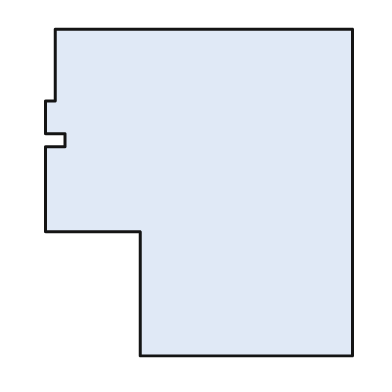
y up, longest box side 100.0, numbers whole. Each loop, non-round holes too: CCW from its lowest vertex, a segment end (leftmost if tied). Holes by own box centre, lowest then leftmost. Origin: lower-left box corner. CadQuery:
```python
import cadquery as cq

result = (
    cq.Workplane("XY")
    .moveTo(29.0, 0.0)
    .lineTo(94.0, 0.0)
    .lineTo(94.0, 100.0)
    .lineTo(3.0, 100.0)
    .lineTo(3.0, 78.0)
    .lineTo(0.0, 78.0)
    .lineTo(0.0, 68.0)
    .lineTo(6.0, 68.0)
    .lineTo(6.0, 64.0)
    .lineTo(0.0, 64.0)
    .lineTo(0.0, 38.0)
    .lineTo(29.0, 38.0)
    .close()
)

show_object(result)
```